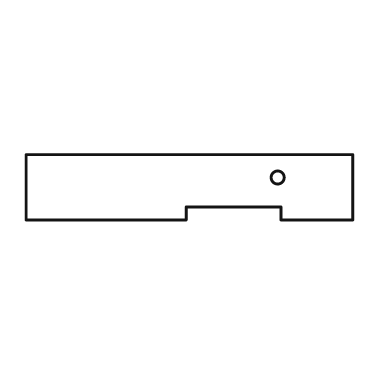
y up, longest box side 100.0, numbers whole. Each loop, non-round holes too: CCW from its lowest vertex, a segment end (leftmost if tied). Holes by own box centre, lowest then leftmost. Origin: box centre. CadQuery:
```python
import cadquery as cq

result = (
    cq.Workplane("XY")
    .moveTo(-50.0, -10.0)
    .lineTo(-1.0, -10.0)
    .lineTo(-1.0, -6.0)
    .lineTo(28.0, -6.0)
    .lineTo(28.0, -10.0)
    .lineTo(50.0, -10.0)
    .lineTo(50.0, 10.0)
    .lineTo(-50.0, 10.0)
    .close()
    .moveTo(27.0, 3.0)
    .circle(2.0)
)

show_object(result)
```